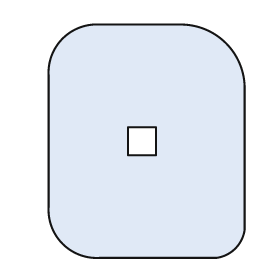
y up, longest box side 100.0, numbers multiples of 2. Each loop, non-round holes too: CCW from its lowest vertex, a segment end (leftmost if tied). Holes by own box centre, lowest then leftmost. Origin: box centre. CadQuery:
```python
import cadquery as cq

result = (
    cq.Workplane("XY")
    .moveTo(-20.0, -50.0)
    .lineTo(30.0, -50.0)
    .threePointArc((38.0, -46.0), (42.0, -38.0))
    .lineTo(42.0, 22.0)
    .threePointArc((34.0, 42.0), (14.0, 50.0))
    .lineTo(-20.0, 50.0)
    .threePointArc((-36.0, 44.0), (-42.0, 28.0))
    .lineTo(-42.0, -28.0)
    .threePointArc((-36.0, -44.0), (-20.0, -50.0))
    .close()
    .moveTo(-8.0, -6.0)
    .lineTo(4.0, -6.0)
    .lineTo(4.0, 6.0)
    .lineTo(-8.0, 6.0)
    .close()
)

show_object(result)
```